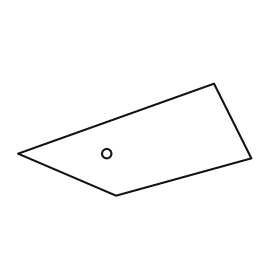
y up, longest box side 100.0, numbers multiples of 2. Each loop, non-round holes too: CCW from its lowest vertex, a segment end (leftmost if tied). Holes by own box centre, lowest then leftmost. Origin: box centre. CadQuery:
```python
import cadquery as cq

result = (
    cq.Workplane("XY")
    .moveTo(-8.0, -24.0)
    .lineTo(50.0, -8.0)
    .lineTo(34.0, 24.0)
    .lineTo(-50.0, -6.0)
    .close()
    .moveTo(-12.0, -6.0)
    .circle(2.0)
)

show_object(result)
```